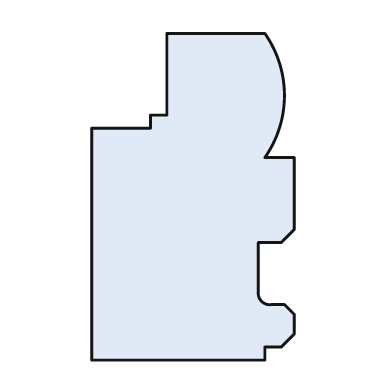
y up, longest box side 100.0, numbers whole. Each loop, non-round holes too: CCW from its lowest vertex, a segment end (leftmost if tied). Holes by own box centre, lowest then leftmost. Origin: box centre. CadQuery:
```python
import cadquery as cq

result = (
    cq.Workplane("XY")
    .moveTo(-31.0, -50.0)
    .lineTo(22.0, -50.0)
    .lineTo(22.0, -46.0)
    .lineTo(27.0, -46.0)
    .lineTo(31.0, -42.0)
    .lineTo(31.0, -36.0)
    .lineTo(28.0, -33.0)
    .lineTo(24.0, -33.0)
    .threePointArc((21.0, -32.0), (20.0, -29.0))
    .lineTo(20.0, -14.0)
    .lineTo(27.0, -14.0)
    .lineTo(31.0, -10.0)
    .lineTo(31.0, 12.0)
    .lineTo(22.0, 12.0)
    .threePointArc((28.0, 31.0), (22.0, 50.0))
    .lineTo(-8.0, 50.0)
    .lineTo(-8.0, 25.0)
    .lineTo(-13.0, 25.0)
    .lineTo(-13.0, 21.0)
    .lineTo(-31.0, 21.0)
    .close()
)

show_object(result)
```